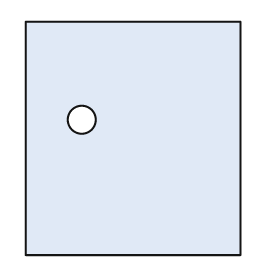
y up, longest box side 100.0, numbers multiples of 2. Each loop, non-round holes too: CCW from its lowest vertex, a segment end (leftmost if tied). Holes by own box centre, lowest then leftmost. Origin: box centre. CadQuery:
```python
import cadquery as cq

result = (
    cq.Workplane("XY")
    .moveTo(-46.0, -50.0)
    .lineTo(46.0, -50.0)
    .lineTo(46.0, 50.0)
    .lineTo(-46.0, 50.0)
    .close()
    .moveTo(-22.0, 8.0)
    .circle(6.0)
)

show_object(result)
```